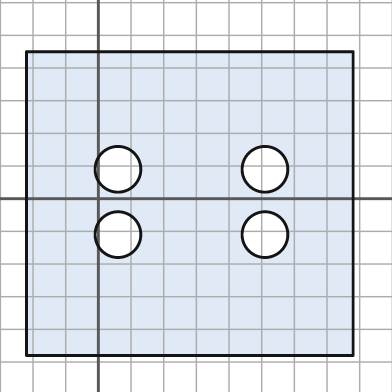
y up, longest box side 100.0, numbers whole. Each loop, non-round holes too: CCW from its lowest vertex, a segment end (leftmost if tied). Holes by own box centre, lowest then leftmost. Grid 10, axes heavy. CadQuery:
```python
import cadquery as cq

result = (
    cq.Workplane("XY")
    .moveTo(-22.0, -48.0)
    .lineTo(78.0, -48.0)
    .lineTo(78.0, 45.0)
    .lineTo(-22.0, 45.0)
    .close()
    .moveTo(6.0, -11.0)
    .circle(7.0)
    .moveTo(51.0, -11.0)
    .circle(7.0)
    .moveTo(6.0, 9.0)
    .circle(7.0)
    .moveTo(51.0, 9.0)
    .circle(7.0)
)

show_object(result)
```